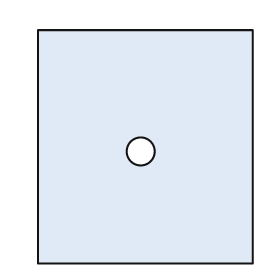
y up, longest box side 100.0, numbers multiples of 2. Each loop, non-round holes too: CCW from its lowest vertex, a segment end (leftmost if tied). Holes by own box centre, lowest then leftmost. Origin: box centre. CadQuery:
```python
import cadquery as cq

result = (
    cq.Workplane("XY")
    .moveTo(-46.0, -50.0)
    .lineTo(46.0, -50.0)
    .lineTo(46.0, 50.0)
    .lineTo(-46.0, 50.0)
    .close()
    .moveTo(-2.0, -2.0)
    .circle(6.0)
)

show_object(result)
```